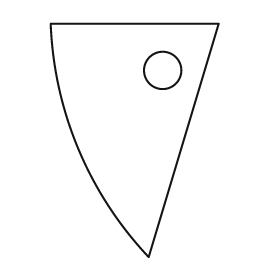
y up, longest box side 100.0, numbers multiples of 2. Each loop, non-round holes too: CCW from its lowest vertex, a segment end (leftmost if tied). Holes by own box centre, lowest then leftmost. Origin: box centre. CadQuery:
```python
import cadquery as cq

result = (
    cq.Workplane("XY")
    .moveTo(6.0, -50.0)
    .lineTo(36.0, 50.0)
    .lineTo(-36.0, 50.0)
    .threePointArc((-24.0, -4.0), (6.0, -50.0))
    .close()
    .moveTo(12.0, 30.0)
    .circle(8.0)
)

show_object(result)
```